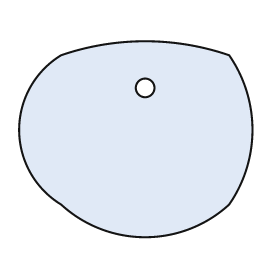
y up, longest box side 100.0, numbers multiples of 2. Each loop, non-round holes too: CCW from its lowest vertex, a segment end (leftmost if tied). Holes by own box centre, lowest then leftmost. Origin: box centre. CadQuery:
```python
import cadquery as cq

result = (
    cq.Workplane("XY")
    .moveTo(-32.0, -28.0)
    .threePointArc((4.0, -42.0), (40.0, -28.0))
    .threePointArc((50.0, 4.0), (40.0, 36.0))
    .threePointArc((4.0, 42.0), (-32.0, 36.0))
    .threePointArc((-50.0, 4.0), (-32.0, -28.0))
    .close()
    .moveTo(4.0, 22.0)
    .circle(4.0)
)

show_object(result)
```